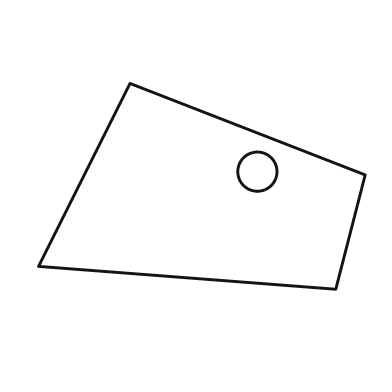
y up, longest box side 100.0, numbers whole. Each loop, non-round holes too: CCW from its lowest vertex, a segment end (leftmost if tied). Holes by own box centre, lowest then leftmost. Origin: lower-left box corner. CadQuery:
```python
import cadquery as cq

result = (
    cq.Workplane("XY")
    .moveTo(91.0, 0.0)
    .lineTo(100.0, 35.0)
    .lineTo(28.0, 63.0)
    .lineTo(0.0, 7.0)
    .close()
    .moveTo(67.0, 36.0)
    .circle(6.0)
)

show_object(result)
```